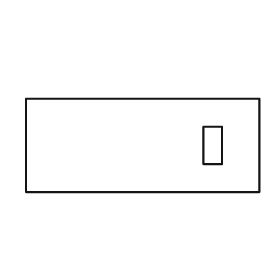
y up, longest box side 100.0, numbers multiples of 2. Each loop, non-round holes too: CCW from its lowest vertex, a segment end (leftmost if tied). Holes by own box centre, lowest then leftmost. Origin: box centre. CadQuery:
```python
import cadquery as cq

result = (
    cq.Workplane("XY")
    .moveTo(-50.0, -20.0)
    .lineTo(50.0, -20.0)
    .lineTo(50.0, 20.0)
    .lineTo(-50.0, 20.0)
    .close()
    .moveTo(26.0, -8.0)
    .lineTo(34.0, -8.0)
    .lineTo(34.0, 8.0)
    .lineTo(26.0, 8.0)
    .close()
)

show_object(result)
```